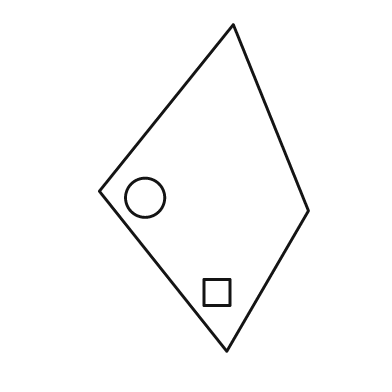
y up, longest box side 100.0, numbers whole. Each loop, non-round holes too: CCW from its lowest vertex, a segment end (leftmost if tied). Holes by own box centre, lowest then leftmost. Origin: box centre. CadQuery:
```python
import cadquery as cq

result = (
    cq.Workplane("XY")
    .moveTo(7.0, -50.0)
    .lineTo(32.0, -7.0)
    .lineTo(9.0, 50.0)
    .lineTo(-32.0, -1.0)
    .close()
    .moveTo(0.0, -36.0)
    .lineTo(8.0, -36.0)
    .lineTo(8.0, -28.0)
    .lineTo(0.0, -28.0)
    .close()
    .moveTo(-18.0, -3.0)
    .circle(6.0)
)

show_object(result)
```